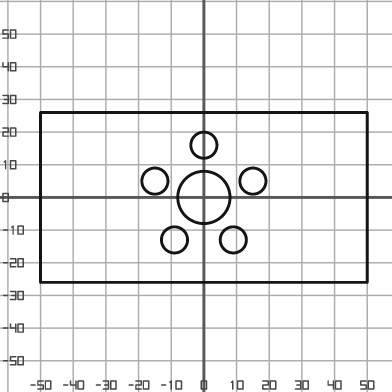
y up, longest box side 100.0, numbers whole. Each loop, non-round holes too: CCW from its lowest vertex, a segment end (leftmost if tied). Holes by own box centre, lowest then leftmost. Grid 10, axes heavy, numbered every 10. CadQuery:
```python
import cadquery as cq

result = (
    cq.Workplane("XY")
    .moveTo(-50.0, -26.0)
    .lineTo(50.0, -26.0)
    .lineTo(50.0, 26.0)
    .lineTo(-50.0, 26.0)
    .close()
    .moveTo(-9.0, -13.0)
    .circle(4.0)
    .moveTo(9.0, -13.0)
    .circle(4.0)
    .moveTo(0.0, 0.0)
    .circle(8.0)
    .moveTo(-15.0, 5.0)
    .circle(4.0)
    .moveTo(15.0, 5.0)
    .circle(4.0)
    .moveTo(0.0, 16.0)
    .circle(4.0)
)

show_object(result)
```